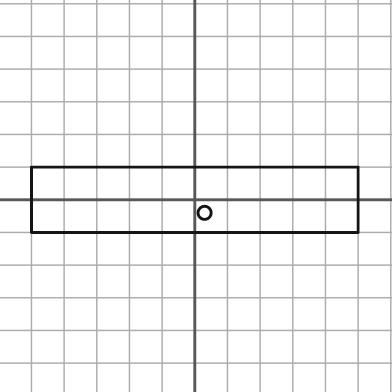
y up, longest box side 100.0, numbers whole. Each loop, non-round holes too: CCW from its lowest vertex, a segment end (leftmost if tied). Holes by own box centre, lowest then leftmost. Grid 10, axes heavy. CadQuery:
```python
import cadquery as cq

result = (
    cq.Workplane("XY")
    .moveTo(-50.0, -10.0)
    .lineTo(50.0, -10.0)
    .lineTo(50.0, 10.0)
    .lineTo(-50.0, 10.0)
    .close()
    .moveTo(3.0, -4.0)
    .circle(2.0)
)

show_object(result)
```